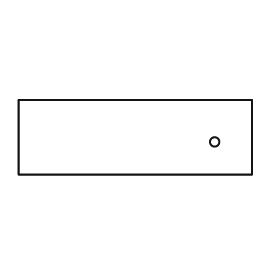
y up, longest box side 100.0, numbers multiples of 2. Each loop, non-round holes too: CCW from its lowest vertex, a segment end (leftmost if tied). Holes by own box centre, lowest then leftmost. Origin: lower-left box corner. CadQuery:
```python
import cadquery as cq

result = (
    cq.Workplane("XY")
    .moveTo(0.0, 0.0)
    .lineTo(100.0, 0.0)
    .lineTo(100.0, 32.0)
    .lineTo(0.0, 32.0)
    .close()
    .moveTo(84.0, 14.0)
    .circle(2.0)
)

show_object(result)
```